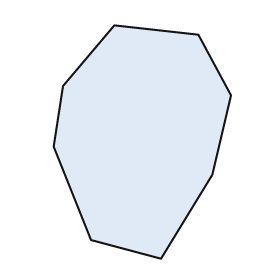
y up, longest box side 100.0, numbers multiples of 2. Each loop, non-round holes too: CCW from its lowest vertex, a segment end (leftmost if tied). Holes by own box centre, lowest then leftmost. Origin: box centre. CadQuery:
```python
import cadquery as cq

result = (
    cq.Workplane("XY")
    .moveTo(8.0, -50.0)
    .lineTo(30.0, -14.0)
    .lineTo(38.0, 20.0)
    .lineTo(24.0, 46.0)
    .lineTo(-12.0, 50.0)
    .lineTo(-34.0, 24.0)
    .lineTo(-38.0, -2.0)
    .lineTo(-22.0, -42.0)
    .close()
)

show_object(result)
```